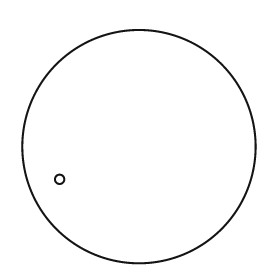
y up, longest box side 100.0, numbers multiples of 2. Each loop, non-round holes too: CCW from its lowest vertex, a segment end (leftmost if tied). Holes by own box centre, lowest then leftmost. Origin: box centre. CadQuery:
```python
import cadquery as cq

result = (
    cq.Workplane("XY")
    .moveTo(0.0, 0.0)
    .circle(50.0)
    .moveTo(-34.0, -14.0)
    .circle(2.0)
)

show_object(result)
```